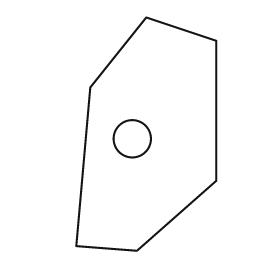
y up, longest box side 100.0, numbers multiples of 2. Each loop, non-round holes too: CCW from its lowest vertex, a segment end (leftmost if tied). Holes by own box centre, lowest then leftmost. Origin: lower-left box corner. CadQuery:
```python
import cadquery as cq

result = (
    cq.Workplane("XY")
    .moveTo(26.0, 0.0)
    .lineTo(60.0, 30.0)
    .lineTo(60.0, 90.0)
    .lineTo(30.0, 100.0)
    .lineTo(6.0, 70.0)
    .lineTo(0.0, 2.0)
    .close()
    .moveTo(24.0, 48.0)
    .circle(8.0)
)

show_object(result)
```